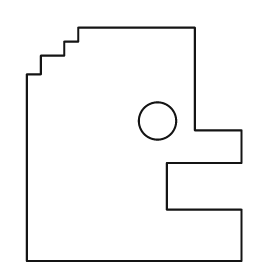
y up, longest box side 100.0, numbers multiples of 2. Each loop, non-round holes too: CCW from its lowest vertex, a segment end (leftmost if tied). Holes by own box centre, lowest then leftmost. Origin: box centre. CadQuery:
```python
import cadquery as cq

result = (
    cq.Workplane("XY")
    .moveTo(-46.0, -50.0)
    .lineTo(46.0, -50.0)
    .lineTo(46.0, -28.0)
    .lineTo(14.0, -28.0)
    .lineTo(14.0, -8.0)
    .lineTo(46.0, -8.0)
    .lineTo(46.0, 6.0)
    .lineTo(26.0, 6.0)
    .lineTo(26.0, 50.0)
    .lineTo(-24.0, 50.0)
    .lineTo(-24.0, 44.0)
    .lineTo(-30.0, 44.0)
    .lineTo(-30.0, 38.0)
    .lineTo(-40.0, 38.0)
    .lineTo(-40.0, 30.0)
    .lineTo(-46.0, 30.0)
    .close()
    .moveTo(10.0, 10.0)
    .circle(8.0)
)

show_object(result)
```